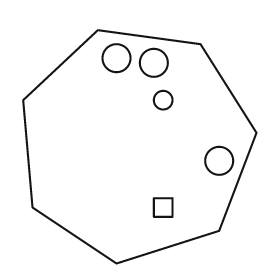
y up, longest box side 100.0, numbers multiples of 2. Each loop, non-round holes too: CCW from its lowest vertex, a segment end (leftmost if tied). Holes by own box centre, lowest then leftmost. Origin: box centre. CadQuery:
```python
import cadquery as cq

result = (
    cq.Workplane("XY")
    .moveTo(-10.0, -50.0)
    .lineTo(34.0, -36.0)
    .lineTo(50.0, 6.0)
    .lineTo(26.0, 44.0)
    .lineTo(-18.0, 50.0)
    .lineTo(-50.0, 20.0)
    .lineTo(-46.0, -26.0)
    .close()
    .moveTo(6.0, -30.0)
    .lineTo(14.0, -30.0)
    .lineTo(14.0, -22.0)
    .lineTo(6.0, -22.0)
    .close()
    .moveTo(34.0, -6.0)
    .circle(6.0)
    .moveTo(10.0, 20.0)
    .circle(4.0)
    .moveTo(6.0, 36.0)
    .circle(6.0)
    .moveTo(-10.0, 38.0)
    .circle(6.0)
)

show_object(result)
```